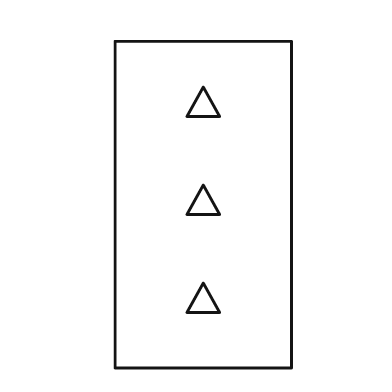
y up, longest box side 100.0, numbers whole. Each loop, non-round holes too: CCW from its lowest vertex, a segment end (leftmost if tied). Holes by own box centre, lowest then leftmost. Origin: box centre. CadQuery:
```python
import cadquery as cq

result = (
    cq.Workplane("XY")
    .moveTo(-27.0, -50.0)
    .lineTo(27.0, -50.0)
    .lineTo(27.0, 50.0)
    .lineTo(-27.0, 50.0)
    .close()
    .moveTo(-5.0, -33.0)
    .lineTo(5.0, -33.0)
    .lineTo(0.0, -24.0)
    .close()
    .moveTo(-5.0, -3.0)
    .lineTo(5.0, -3.0)
    .lineTo(0.0, 6.0)
    .close()
    .moveTo(-5.0, 27.0)
    .lineTo(5.0, 27.0)
    .lineTo(0.0, 36.0)
    .close()
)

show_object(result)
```